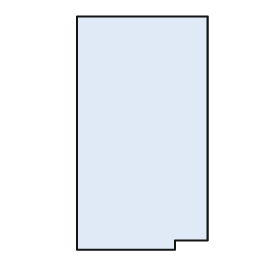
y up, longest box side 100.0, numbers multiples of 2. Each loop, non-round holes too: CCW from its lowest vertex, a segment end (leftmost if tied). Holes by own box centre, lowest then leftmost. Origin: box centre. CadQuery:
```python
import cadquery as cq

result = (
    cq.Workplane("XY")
    .moveTo(-28.0, -50.0)
    .lineTo(14.0, -50.0)
    .lineTo(14.0, -46.0)
    .lineTo(28.0, -46.0)
    .lineTo(28.0, 50.0)
    .lineTo(-28.0, 50.0)
    .close()
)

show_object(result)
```